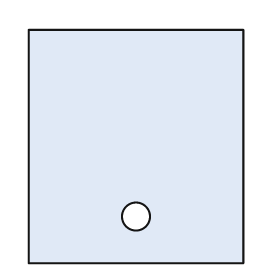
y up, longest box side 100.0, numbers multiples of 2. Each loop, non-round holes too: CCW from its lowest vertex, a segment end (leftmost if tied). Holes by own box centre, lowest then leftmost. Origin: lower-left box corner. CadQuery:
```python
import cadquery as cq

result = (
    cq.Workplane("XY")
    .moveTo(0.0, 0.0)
    .lineTo(92.0, 0.0)
    .lineTo(92.0, 100.0)
    .lineTo(0.0, 100.0)
    .close()
    .moveTo(46.0, 20.0)
    .circle(6.0)
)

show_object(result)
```